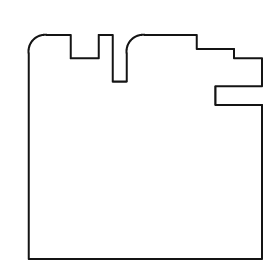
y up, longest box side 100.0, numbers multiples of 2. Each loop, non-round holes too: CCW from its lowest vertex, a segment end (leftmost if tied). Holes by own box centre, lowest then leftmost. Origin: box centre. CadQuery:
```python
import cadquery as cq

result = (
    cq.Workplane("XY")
    .moveTo(-50.0, -48.0)
    .lineTo(50.0, -48.0)
    .lineTo(50.0, 18.0)
    .lineTo(30.0, 18.0)
    .lineTo(30.0, 26.0)
    .lineTo(50.0, 26.0)
    .lineTo(50.0, 38.0)
    .lineTo(38.0, 38.0)
    .lineTo(38.0, 42.0)
    .lineTo(22.0, 42.0)
    .lineTo(22.0, 48.0)
    .lineTo(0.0, 48.0)
    .threePointArc((-6.0, 46.0), (-8.0, 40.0))
    .lineTo(-8.0, 28.0)
    .lineTo(-14.0, 28.0)
    .lineTo(-14.0, 48.0)
    .lineTo(-20.0, 48.0)
    .lineTo(-20.0, 38.0)
    .lineTo(-32.0, 38.0)
    .lineTo(-32.0, 48.0)
    .lineTo(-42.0, 48.0)
    .threePointArc((-48.0, 46.0), (-50.0, 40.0))
    .close()
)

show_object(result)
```